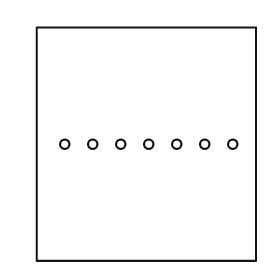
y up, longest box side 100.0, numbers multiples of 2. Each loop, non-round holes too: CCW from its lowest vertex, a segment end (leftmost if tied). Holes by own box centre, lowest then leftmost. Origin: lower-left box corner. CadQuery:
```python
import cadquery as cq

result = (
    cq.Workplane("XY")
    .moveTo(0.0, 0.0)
    .lineTo(94.0, 0.0)
    .lineTo(94.0, 100.0)
    .lineTo(0.0, 100.0)
    .close()
    .moveTo(12.0, 50.0)
    .circle(2.0)
    .moveTo(24.0, 50.0)
    .circle(2.0)
    .moveTo(36.0, 50.0)
    .circle(2.0)
    .moveTo(48.0, 50.0)
    .circle(2.0)
    .moveTo(60.0, 50.0)
    .circle(2.0)
    .moveTo(72.0, 50.0)
    .circle(2.0)
    .moveTo(84.0, 50.0)
    .circle(2.0)
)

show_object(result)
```